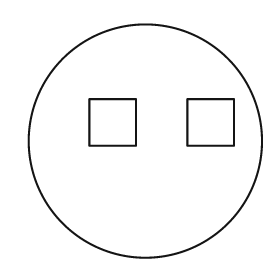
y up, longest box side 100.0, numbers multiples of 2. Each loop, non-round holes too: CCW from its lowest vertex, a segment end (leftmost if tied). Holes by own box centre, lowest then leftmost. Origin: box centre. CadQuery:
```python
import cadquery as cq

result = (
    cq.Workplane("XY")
    .moveTo(0.0, 0.0)
    .circle(50.0)
    .moveTo(-24.0, -2.0)
    .lineTo(-4.0, -2.0)
    .lineTo(-4.0, 18.0)
    .lineTo(-24.0, 18.0)
    .close()
    .moveTo(18.0, -2.0)
    .lineTo(38.0, -2.0)
    .lineTo(38.0, 18.0)
    .lineTo(18.0, 18.0)
    .close()
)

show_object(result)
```